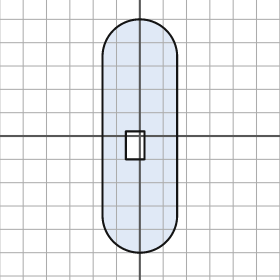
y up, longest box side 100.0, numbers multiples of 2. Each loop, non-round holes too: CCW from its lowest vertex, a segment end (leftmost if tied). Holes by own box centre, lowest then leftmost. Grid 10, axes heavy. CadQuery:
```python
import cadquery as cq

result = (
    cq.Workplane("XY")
    .moveTo(-16.0, -34.0)
    .threePointArc((0.0, -50.0), (16.0, -34.0))
    .lineTo(16.0, 34.0)
    .threePointArc((0.0, 50.0), (-16.0, 34.0))
    .close()
    .moveTo(-6.0, -10.0)
    .lineTo(2.0, -10.0)
    .lineTo(2.0, 2.0)
    .lineTo(-6.0, 2.0)
    .close()
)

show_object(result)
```